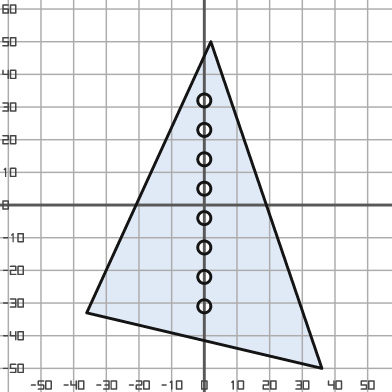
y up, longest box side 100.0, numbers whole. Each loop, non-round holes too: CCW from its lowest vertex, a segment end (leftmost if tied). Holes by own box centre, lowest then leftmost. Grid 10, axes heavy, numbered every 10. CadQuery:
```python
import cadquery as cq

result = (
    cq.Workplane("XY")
    .moveTo(36.0, -50.0)
    .lineTo(2.0, 50.0)
    .lineTo(-36.0, -33.0)
    .close()
    .moveTo(0.0, -31.0)
    .circle(2.0)
    .moveTo(0.0, -22.0)
    .circle(2.0)
    .moveTo(0.0, -13.0)
    .circle(2.0)
    .moveTo(0.0, -4.0)
    .circle(2.0)
    .moveTo(0.0, 5.0)
    .circle(2.0)
    .moveTo(0.0, 14.0)
    .circle(2.0)
    .moveTo(0.0, 23.0)
    .circle(2.0)
    .moveTo(0.0, 32.0)
    .circle(2.0)
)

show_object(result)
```